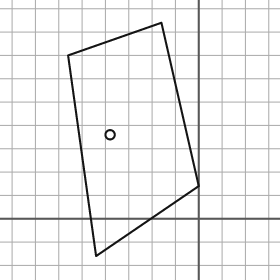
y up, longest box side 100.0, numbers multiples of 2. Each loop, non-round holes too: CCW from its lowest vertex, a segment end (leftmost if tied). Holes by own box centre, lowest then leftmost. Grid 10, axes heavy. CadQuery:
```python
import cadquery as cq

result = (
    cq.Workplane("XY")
    .moveTo(-44.0, -16.0)
    .lineTo(0.0, 14.0)
    .lineTo(-16.0, 84.0)
    .lineTo(-56.0, 70.0)
    .close()
    .moveTo(-38.0, 36.0)
    .circle(2.0)
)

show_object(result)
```